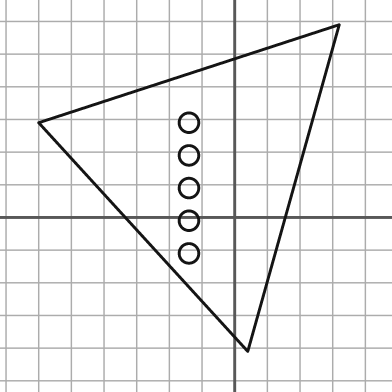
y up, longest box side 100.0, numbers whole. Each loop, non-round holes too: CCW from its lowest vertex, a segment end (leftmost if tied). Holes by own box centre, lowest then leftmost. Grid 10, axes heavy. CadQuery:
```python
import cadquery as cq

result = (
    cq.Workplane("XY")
    .moveTo(4.0, -41.0)
    .lineTo(32.0, 59.0)
    .lineTo(-60.0, 29.0)
    .close()
    .moveTo(-14.0, -11.0)
    .circle(3.0)
    .moveTo(-14.0, -1.0)
    .circle(3.0)
    .moveTo(-14.0, 9.0)
    .circle(3.0)
    .moveTo(-14.0, 19.0)
    .circle(3.0)
    .moveTo(-14.0, 29.0)
    .circle(3.0)
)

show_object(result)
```